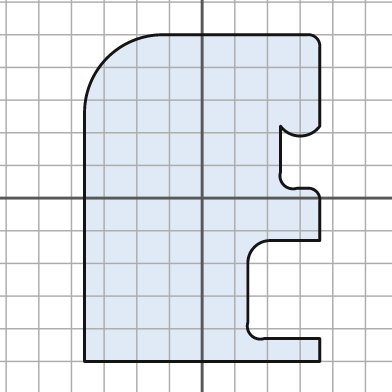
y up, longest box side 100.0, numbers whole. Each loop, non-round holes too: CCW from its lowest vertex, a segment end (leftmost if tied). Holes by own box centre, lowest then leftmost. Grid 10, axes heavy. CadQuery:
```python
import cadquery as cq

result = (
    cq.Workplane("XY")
    .moveTo(-36.0, -50.0)
    .lineTo(36.0, -50.0)
    .lineTo(36.0, -43.0)
    .lineTo(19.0, -43.0)
    .threePointArc((15.0, -42.0), (14.0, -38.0))
    .lineTo(14.0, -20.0)
    .threePointArc((16.0, -15.0), (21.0, -13.0))
    .lineTo(36.0, -13.0)
    .lineTo(36.0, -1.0)
    .threePointArc((35.0, 2.0), (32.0, 3.0))
    .lineTo(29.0, 3.0)
    .threePointArc((25.0, 4.0), (24.0, 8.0))
    .lineTo(24.0, 22.0)
    .threePointArc((30.0, 19.0), (36.0, 22.0))
    .lineTo(36.0, 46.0)
    .threePointArc((35.0, 49.0), (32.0, 50.0))
    .lineTo(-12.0, 50.0)
    .threePointArc((-29.0, 43.0), (-36.0, 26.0))
    .close()
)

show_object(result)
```